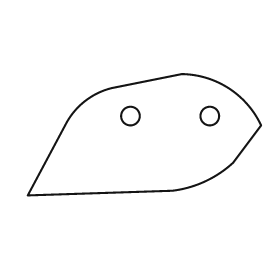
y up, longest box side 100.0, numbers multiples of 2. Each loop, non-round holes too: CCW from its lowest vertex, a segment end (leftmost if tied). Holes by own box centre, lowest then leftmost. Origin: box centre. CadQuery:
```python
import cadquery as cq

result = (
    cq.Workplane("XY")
    .moveTo(-50.0, -26.0)
    .lineTo(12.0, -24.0)
    .threePointArc((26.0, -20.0), (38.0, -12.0))
    .lineTo(50.0, 4.0)
    .threePointArc((36.0, 20.0), (16.0, 26.0))
    .lineTo(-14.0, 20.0)
    .threePointArc((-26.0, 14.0), (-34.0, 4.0))
    .close()
    .moveTo(-6.0, 8.0)
    .circle(4.0)
    .moveTo(28.0, 8.0)
    .circle(4.0)
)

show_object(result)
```